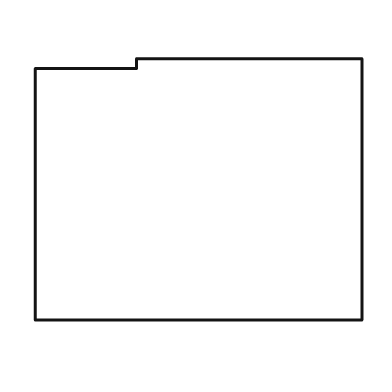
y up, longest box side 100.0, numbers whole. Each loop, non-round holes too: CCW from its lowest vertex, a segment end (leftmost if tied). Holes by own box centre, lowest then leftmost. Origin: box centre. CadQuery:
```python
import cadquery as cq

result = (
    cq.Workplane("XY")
    .moveTo(-50.0, -40.0)
    .lineTo(50.0, -40.0)
    .lineTo(50.0, 40.0)
    .lineTo(-19.0, 40.0)
    .lineTo(-19.0, 37.0)
    .lineTo(-50.0, 37.0)
    .close()
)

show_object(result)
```